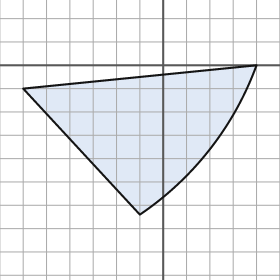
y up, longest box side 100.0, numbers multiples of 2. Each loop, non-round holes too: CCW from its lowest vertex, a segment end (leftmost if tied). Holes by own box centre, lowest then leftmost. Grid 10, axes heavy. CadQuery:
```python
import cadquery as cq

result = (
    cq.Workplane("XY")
    .moveTo(-10.0, -64.0)
    .threePointArc((20.0, -36.0), (40.0, 0.0))
    .lineTo(-60.0, -10.0)
    .close()
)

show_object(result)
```